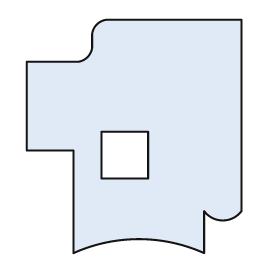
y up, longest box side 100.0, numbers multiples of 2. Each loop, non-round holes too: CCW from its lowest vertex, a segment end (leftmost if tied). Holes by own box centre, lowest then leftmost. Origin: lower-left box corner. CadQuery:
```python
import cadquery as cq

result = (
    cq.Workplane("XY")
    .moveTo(20.0, 0.0)
    .threePointArc((48.0, 6.0), (76.0, 0.0))
    .lineTo(76.0, 18.0)
    .threePointArc((84.0, 14.0), (92.0, 18.0))
    .lineTo(92.0, 100.0)
    .lineTo(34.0, 100.0)
    .threePointArc((30.0, 98.0), (28.0, 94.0))
    .lineTo(28.0, 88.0)
    .threePointArc((26.0, 84.0), (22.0, 82.0))
    .lineTo(0.0, 82.0)
    .lineTo(0.0, 44.0)
    .lineTo(20.0, 44.0)
    .close()
    .moveTo(32.0, 32.0)
    .lineTo(52.0, 32.0)
    .lineTo(52.0, 52.0)
    .lineTo(32.0, 52.0)
    .close()
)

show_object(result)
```